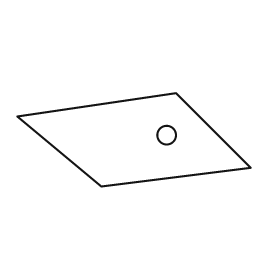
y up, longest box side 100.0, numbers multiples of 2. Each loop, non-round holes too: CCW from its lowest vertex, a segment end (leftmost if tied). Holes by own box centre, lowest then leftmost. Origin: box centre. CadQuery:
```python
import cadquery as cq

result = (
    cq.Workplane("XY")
    .moveTo(-14.0, -20.0)
    .lineTo(50.0, -12.0)
    .lineTo(18.0, 20.0)
    .lineTo(-50.0, 10.0)
    .close()
    .moveTo(14.0, 2.0)
    .circle(4.0)
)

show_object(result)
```